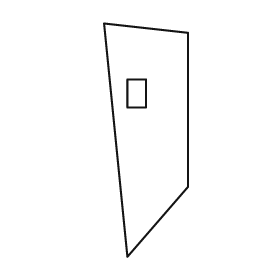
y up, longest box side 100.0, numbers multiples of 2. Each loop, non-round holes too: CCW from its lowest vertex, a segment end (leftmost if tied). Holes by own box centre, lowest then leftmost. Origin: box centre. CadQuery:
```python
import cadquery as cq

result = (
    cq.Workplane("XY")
    .moveTo(-8.0, -50.0)
    .lineTo(18.0, -20.0)
    .lineTo(18.0, 46.0)
    .lineTo(-18.0, 50.0)
    .close()
    .moveTo(-8.0, 14.0)
    .lineTo(0.0, 14.0)
    .lineTo(0.0, 26.0)
    .lineTo(-8.0, 26.0)
    .close()
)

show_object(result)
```